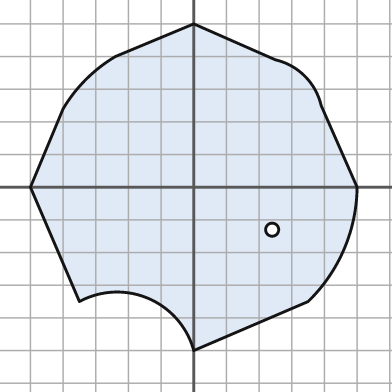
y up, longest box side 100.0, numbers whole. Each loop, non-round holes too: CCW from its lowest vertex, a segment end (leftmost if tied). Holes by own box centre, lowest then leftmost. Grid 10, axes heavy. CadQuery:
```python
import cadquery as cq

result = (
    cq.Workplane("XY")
    .moveTo(0.0, -50.0)
    .lineTo(35.0, -35.0)
    .threePointArc((46.0, -19.0), (50.0, 0.0))
    .lineTo(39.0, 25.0)
    .threePointArc((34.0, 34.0), (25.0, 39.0))
    .lineTo(0.0, 50.0)
    .lineTo(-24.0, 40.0)
    .threePointArc((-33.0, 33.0), (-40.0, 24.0))
    .lineTo(-50.0, 0.0)
    .lineTo(-35.0, -35.0)
    .threePointArc((-14.0, -34.0), (0.0, -50.0))
    .close()
    .moveTo(24.0, -13.0)
    .circle(2.0)
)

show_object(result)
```